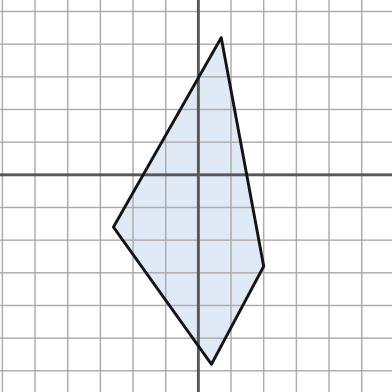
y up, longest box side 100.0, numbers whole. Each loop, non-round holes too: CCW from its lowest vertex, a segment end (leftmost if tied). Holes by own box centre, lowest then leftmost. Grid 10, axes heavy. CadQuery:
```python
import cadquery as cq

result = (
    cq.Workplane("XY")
    .moveTo(4.0, -58.0)
    .lineTo(20.0, -28.0)
    .lineTo(7.0, 42.0)
    .lineTo(-26.0, -16.0)
    .close()
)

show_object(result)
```